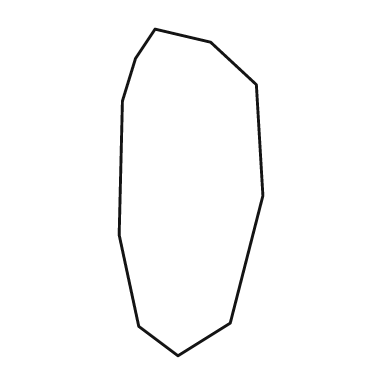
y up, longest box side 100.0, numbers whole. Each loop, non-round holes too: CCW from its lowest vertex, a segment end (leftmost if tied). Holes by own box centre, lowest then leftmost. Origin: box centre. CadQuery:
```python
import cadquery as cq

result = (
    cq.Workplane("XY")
    .moveTo(-4.0, -50.0)
    .lineTo(12.0, -40.0)
    .lineTo(22.0, -1.0)
    .lineTo(20.0, 33.0)
    .lineTo(6.0, 46.0)
    .lineTo(-11.0, 50.0)
    .lineTo(-17.0, 41.0)
    .lineTo(-21.0, 28.0)
    .lineTo(-22.0, -13.0)
    .lineTo(-16.0, -41.0)
    .close()
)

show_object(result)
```